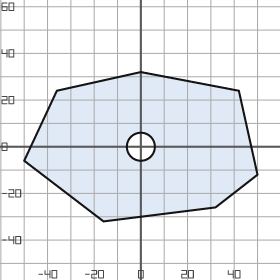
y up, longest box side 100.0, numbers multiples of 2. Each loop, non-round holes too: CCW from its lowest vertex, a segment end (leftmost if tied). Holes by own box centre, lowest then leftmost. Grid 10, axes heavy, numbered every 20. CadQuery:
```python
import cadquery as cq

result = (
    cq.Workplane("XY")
    .moveTo(-16.0, -32.0)
    .lineTo(32.0, -26.0)
    .lineTo(50.0, -12.0)
    .lineTo(42.0, 24.0)
    .lineTo(0.0, 32.0)
    .lineTo(-36.0, 24.0)
    .lineTo(-50.0, -6.0)
    .close()
    .moveTo(0.0, 0.0)
    .circle(6.0)
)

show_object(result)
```